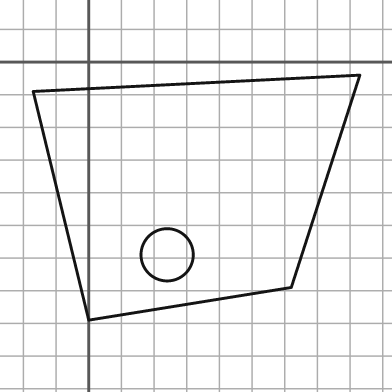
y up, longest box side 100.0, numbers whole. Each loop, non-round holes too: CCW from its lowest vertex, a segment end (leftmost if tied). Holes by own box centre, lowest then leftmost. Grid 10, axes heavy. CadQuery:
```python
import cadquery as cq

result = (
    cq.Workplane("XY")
    .moveTo(0.0, -79.0)
    .lineTo(62.0, -69.0)
    .lineTo(83.0, -4.0)
    .lineTo(-17.0, -9.0)
    .close()
    .moveTo(24.0, -59.0)
    .circle(8.0)
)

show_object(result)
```